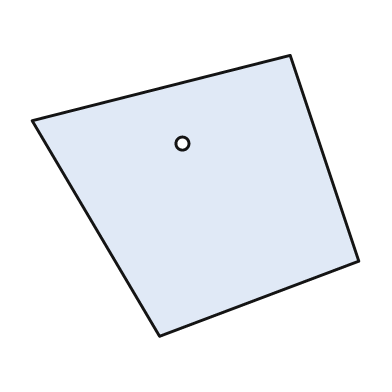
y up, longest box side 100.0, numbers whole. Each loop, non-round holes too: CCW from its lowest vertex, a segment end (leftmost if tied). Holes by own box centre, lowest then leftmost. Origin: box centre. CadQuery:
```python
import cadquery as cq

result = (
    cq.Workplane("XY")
    .moveTo(-11.0, -43.0)
    .lineTo(50.0, -20.0)
    .lineTo(29.0, 43.0)
    .lineTo(-50.0, 23.0)
    .close()
    .moveTo(-4.0, 16.0)
    .circle(2.0)
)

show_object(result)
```